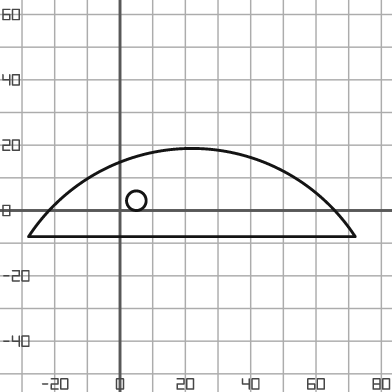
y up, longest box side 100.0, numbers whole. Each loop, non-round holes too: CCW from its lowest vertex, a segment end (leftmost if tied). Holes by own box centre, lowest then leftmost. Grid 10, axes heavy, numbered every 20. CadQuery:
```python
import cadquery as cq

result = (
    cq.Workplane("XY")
    .moveTo(-28.0, -8.0)
    .lineTo(72.0, -8.0)
    .threePointArc((22.0, 19.0), (-28.0, -8.0))
    .close()
    .moveTo(5.0, 3.0)
    .circle(3.0)
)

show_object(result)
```